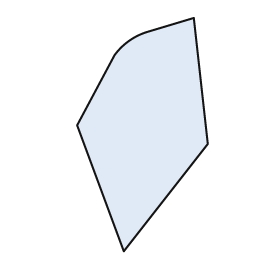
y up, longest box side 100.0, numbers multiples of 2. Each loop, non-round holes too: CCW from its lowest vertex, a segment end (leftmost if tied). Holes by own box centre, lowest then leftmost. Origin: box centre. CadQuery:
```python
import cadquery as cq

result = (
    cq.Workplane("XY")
    .moveTo(-8.0, -50.0)
    .lineTo(28.0, -4.0)
    .lineTo(22.0, 50.0)
    .lineTo(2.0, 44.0)
    .threePointArc((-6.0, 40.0), (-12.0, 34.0))
    .lineTo(-28.0, 4.0)
    .close()
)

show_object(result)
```